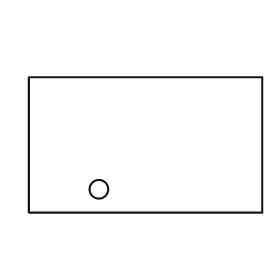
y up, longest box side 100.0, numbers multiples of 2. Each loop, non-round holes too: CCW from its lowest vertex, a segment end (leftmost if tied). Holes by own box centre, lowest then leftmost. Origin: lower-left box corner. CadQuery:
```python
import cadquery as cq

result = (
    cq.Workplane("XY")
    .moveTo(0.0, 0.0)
    .lineTo(100.0, 0.0)
    .lineTo(100.0, 58.0)
    .lineTo(0.0, 58.0)
    .close()
    .moveTo(30.0, 10.0)
    .circle(4.0)
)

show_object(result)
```